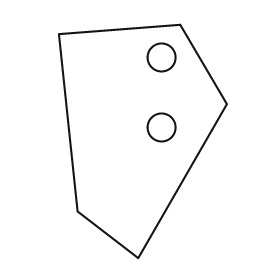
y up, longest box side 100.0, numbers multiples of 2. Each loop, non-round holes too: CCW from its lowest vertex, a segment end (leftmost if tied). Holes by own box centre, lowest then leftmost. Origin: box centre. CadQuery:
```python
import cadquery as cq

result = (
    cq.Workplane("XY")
    .moveTo(-2.0, -50.0)
    .lineTo(36.0, 16.0)
    .lineTo(16.0, 50.0)
    .lineTo(-36.0, 46.0)
    .lineTo(-28.0, -30.0)
    .close()
    .moveTo(8.0, 6.0)
    .circle(6.0)
    .moveTo(8.0, 36.0)
    .circle(6.0)
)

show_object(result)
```